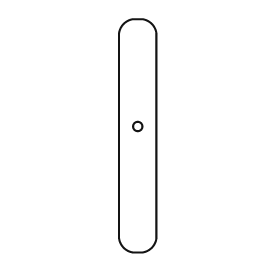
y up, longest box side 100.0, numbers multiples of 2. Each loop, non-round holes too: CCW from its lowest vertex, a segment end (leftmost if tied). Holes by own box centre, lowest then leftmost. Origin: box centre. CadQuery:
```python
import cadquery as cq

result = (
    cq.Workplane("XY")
    .moveTo(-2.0, -50.0)
    .lineTo(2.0, -50.0)
    .threePointArc((6.0, -48.0), (8.0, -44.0))
    .lineTo(8.0, 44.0)
    .threePointArc((6.0, 48.0), (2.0, 50.0))
    .lineTo(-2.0, 50.0)
    .threePointArc((-6.0, 48.0), (-8.0, 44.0))
    .lineTo(-8.0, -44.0)
    .threePointArc((-6.0, -48.0), (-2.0, -50.0))
    .close()
    .moveTo(0.0, 4.0)
    .circle(2.0)
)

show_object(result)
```